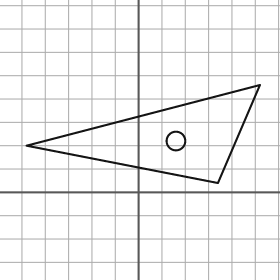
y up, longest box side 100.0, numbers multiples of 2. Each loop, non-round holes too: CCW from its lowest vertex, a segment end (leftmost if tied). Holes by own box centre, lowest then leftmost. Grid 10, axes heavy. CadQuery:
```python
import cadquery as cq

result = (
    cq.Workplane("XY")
    .moveTo(34.0, 4.0)
    .lineTo(52.0, 46.0)
    .lineTo(-48.0, 20.0)
    .close()
    .moveTo(16.0, 22.0)
    .circle(4.0)
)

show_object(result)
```